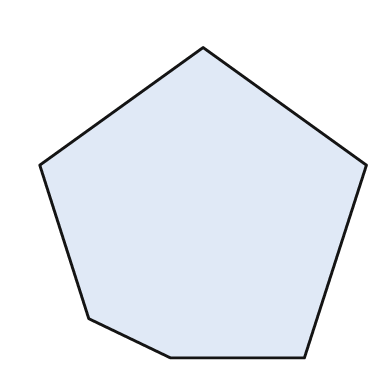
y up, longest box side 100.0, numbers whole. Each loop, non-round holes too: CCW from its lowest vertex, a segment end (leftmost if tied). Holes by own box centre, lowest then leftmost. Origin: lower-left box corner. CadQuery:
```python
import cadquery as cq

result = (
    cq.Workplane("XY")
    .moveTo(40.0, 0.0)
    .lineTo(81.0, 0.0)
    .lineTo(100.0, 59.0)
    .lineTo(50.0, 95.0)
    .lineTo(0.0, 59.0)
    .lineTo(15.0, 12.0)
    .close()
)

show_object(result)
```